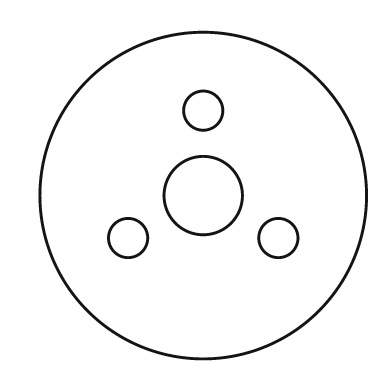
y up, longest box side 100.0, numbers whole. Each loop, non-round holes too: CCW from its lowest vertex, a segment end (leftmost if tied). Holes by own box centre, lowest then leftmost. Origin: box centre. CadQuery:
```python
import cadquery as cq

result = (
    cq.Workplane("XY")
    .moveTo(0.0, 0.0)
    .circle(50.0)
    .moveTo(-23.0, -13.0)
    .circle(6.0)
    .moveTo(23.0, -13.0)
    .circle(6.0)
    .moveTo(0.0, 0.0)
    .circle(12.0)
    .moveTo(0.0, 26.0)
    .circle(6.0)
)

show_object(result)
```